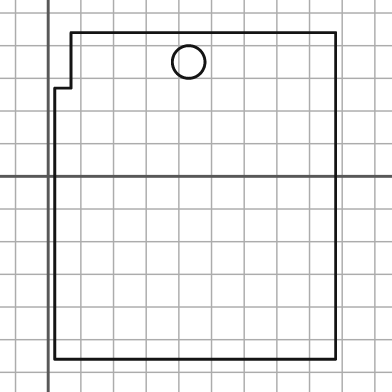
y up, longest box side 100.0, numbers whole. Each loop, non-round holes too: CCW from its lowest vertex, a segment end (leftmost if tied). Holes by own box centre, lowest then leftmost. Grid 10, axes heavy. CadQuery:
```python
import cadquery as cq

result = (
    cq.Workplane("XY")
    .moveTo(2.0, -56.0)
    .lineTo(88.0, -56.0)
    .lineTo(88.0, 44.0)
    .lineTo(7.0, 44.0)
    .lineTo(7.0, 27.0)
    .lineTo(2.0, 27.0)
    .close()
    .moveTo(43.0, 35.0)
    .circle(5.0)
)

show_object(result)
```